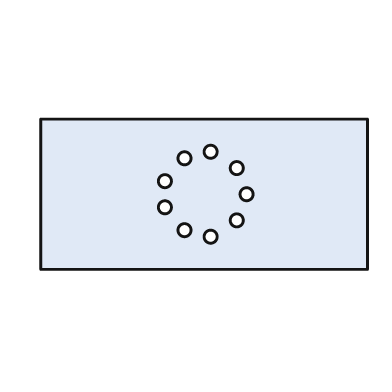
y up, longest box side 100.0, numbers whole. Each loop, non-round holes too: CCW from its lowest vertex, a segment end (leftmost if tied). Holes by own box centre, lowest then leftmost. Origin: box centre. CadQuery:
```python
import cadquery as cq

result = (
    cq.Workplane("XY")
    .moveTo(-50.0, -23.0)
    .lineTo(50.0, -23.0)
    .lineTo(50.0, 23.0)
    .lineTo(-50.0, 23.0)
    .close()
    .moveTo(2.0, -13.0)
    .circle(2.0)
    .moveTo(-6.0, -11.0)
    .circle(2.0)
    .moveTo(10.0, -8.0)
    .circle(2.0)
    .moveTo(-12.0, -4.0)
    .circle(2.0)
    .moveTo(13.0, 0.0)
    .circle(2.0)
    .moveTo(-12.0, 4.0)
    .circle(2.0)
    .moveTo(10.0, 8.0)
    .circle(2.0)
    .moveTo(-6.0, 11.0)
    .circle(2.0)
    .moveTo(2.0, 13.0)
    .circle(2.0)
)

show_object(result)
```